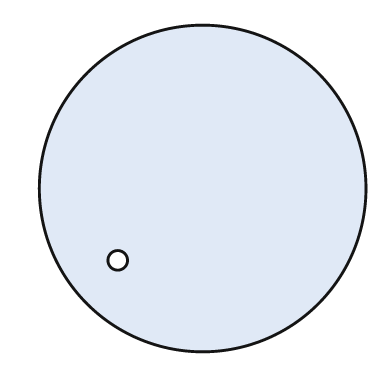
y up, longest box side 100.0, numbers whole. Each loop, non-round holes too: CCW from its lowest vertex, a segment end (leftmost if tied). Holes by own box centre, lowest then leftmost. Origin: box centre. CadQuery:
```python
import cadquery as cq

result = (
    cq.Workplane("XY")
    .moveTo(0.0, 0.0)
    .circle(50.0)
    .moveTo(-26.0, -22.0)
    .circle(3.0)
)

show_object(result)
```